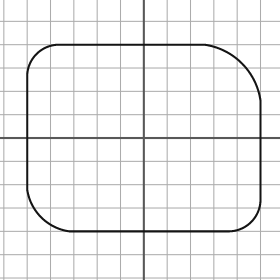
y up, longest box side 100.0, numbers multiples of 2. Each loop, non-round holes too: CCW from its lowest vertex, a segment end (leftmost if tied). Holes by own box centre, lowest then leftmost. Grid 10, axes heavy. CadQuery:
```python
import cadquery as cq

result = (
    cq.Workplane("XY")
    .moveTo(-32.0, -40.0)
    .lineTo(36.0, -40.0)
    .threePointArc((46.0, -36.0), (50.0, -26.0))
    .lineTo(50.0, 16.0)
    .threePointArc((42.0, 32.0), (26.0, 40.0))
    .lineTo(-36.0, 40.0)
    .threePointArc((-46.0, 36.0), (-50.0, 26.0))
    .lineTo(-50.0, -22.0)
    .threePointArc((-44.0, -34.0), (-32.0, -40.0))
    .close()
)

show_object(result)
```